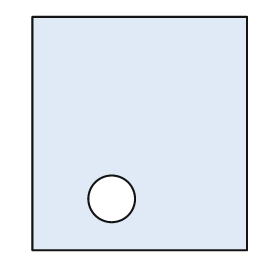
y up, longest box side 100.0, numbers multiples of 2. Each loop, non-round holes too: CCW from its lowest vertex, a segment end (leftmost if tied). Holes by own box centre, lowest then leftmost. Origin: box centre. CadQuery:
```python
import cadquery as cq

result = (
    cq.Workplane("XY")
    .moveTo(-46.0, -50.0)
    .lineTo(46.0, -50.0)
    .lineTo(46.0, 50.0)
    .lineTo(-46.0, 50.0)
    .close()
    .moveTo(-12.0, -28.0)
    .circle(10.0)
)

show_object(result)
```